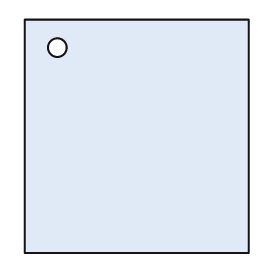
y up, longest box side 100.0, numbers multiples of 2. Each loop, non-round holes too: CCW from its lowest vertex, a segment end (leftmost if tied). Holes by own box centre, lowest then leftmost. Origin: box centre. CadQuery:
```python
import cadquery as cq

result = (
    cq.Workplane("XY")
    .moveTo(-48.0, -50.0)
    .lineTo(48.0, -50.0)
    .lineTo(48.0, 50.0)
    .lineTo(-48.0, 50.0)
    .close()
    .moveTo(-34.0, 38.0)
    .circle(4.0)
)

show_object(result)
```